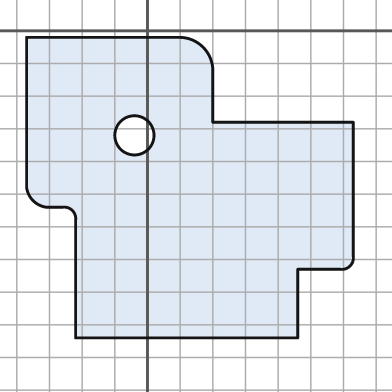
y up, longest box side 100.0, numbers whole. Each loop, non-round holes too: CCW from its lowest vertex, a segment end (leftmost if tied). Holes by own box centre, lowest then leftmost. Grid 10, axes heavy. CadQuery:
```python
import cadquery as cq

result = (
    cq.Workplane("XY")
    .moveTo(-22.0, -94.0)
    .lineTo(46.0, -94.0)
    .lineTo(46.0, -73.0)
    .lineTo(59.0, -73.0)
    .threePointArc((62.0, -72.0), (63.0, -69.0))
    .lineTo(63.0, -28.0)
    .lineTo(20.0, -28.0)
    .lineTo(20.0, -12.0)
    .threePointArc((17.0, -5.0), (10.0, -2.0))
    .lineTo(-37.0, -2.0)
    .lineTo(-37.0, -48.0)
    .threePointArc((-35.0, -52.0), (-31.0, -54.0))
    .lineTo(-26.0, -54.0)
    .threePointArc((-23.0, -55.0), (-22.0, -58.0))
    .close()
    .moveTo(-4.0, -32.0)
    .circle(6.0)
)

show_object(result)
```